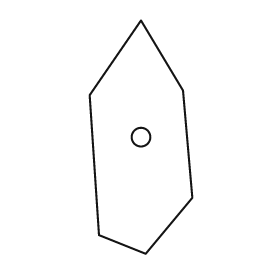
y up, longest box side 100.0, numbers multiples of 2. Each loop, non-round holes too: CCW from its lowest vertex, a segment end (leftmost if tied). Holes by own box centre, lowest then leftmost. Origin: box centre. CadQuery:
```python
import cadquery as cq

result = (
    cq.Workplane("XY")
    .moveTo(2.0, -50.0)
    .lineTo(22.0, -26.0)
    .lineTo(18.0, 20.0)
    .lineTo(0.0, 50.0)
    .lineTo(-22.0, 18.0)
    .lineTo(-18.0, -42.0)
    .close()
    .moveTo(0.0, 0.0)
    .circle(4.0)
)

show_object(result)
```